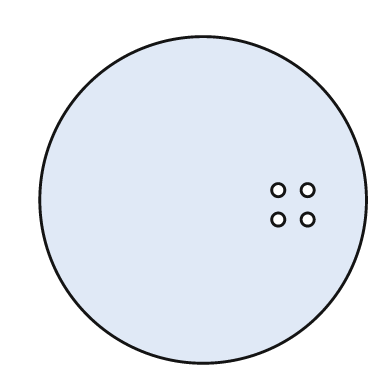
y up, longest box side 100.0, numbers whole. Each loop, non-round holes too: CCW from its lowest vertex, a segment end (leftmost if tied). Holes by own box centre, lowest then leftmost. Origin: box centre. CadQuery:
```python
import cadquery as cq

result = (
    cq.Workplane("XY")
    .moveTo(0.0, 0.0)
    .circle(50.0)
    .moveTo(23.0, -6.0)
    .circle(2.0)
    .moveTo(32.0, -6.0)
    .circle(2.0)
    .moveTo(23.0, 3.0)
    .circle(2.0)
    .moveTo(32.0, 3.0)
    .circle(2.0)
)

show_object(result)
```